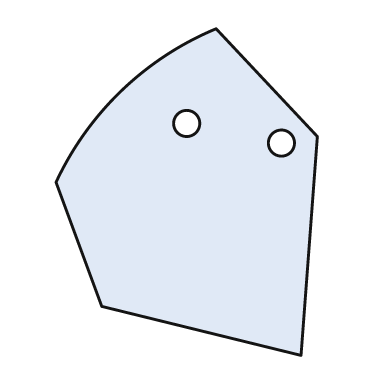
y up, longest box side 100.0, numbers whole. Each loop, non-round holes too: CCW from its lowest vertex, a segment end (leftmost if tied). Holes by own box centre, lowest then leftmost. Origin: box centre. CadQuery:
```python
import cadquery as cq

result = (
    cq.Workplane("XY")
    .moveTo(35.0, -50.0)
    .lineTo(40.0, 17.0)
    .lineTo(9.0, 50.0)
    .threePointArc((-20.0, 31.0), (-40.0, 3.0))
    .lineTo(-26.0, -35.0)
    .close()
    .moveTo(29.0, 15.0)
    .circle(4.0)
    .moveTo(0.0, 21.0)
    .circle(4.0)
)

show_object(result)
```